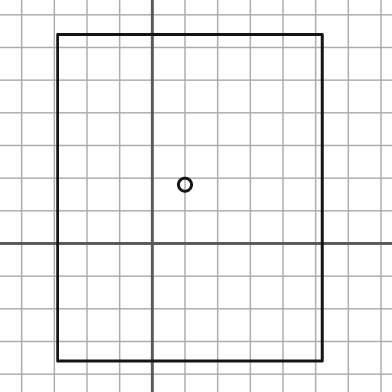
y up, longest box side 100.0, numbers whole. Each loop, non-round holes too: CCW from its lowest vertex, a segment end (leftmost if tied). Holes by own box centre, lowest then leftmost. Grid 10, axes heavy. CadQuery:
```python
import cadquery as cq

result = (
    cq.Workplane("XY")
    .moveTo(-29.0, -36.0)
    .lineTo(52.0, -36.0)
    .lineTo(52.0, 64.0)
    .lineTo(-29.0, 64.0)
    .close()
    .moveTo(10.0, 18.0)
    .circle(2.0)
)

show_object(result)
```